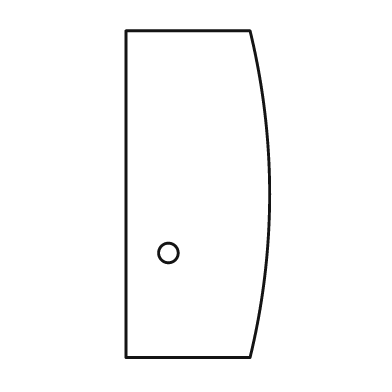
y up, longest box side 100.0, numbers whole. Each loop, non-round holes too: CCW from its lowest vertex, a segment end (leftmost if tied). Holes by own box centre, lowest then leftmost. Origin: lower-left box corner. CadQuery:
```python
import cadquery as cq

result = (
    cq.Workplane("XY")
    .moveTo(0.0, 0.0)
    .lineTo(38.0, 0.0)
    .threePointArc((44.0, 50.0), (38.0, 100.0))
    .lineTo(0.0, 100.0)
    .close()
    .moveTo(13.0, 32.0)
    .circle(3.0)
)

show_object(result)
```